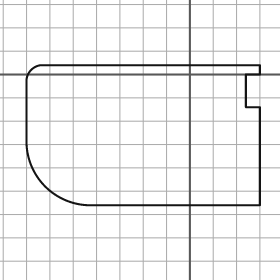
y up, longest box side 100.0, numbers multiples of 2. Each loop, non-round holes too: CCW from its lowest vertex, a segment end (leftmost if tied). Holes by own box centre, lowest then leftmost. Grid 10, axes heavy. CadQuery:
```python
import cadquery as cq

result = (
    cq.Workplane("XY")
    .moveTo(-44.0, -56.0)
    .lineTo(30.0, -56.0)
    .lineTo(30.0, -14.0)
    .lineTo(24.0, -14.0)
    .lineTo(24.0, 0.0)
    .lineTo(30.0, 0.0)
    .lineTo(30.0, 4.0)
    .lineTo(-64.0, 4.0)
    .threePointArc((-68.0, 2.0), (-70.0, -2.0))
    .lineTo(-70.0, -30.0)
    .threePointArc((-62.0, -48.0), (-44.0, -56.0))
    .close()
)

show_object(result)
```